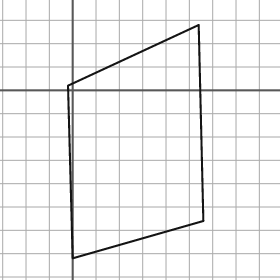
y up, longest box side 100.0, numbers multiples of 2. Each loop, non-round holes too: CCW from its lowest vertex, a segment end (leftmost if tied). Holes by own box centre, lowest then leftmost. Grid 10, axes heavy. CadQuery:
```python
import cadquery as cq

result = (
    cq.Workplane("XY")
    .moveTo(0.0, -72.0)
    .lineTo(56.0, -56.0)
    .lineTo(54.0, 28.0)
    .lineTo(-2.0, 2.0)
    .close()
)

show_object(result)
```